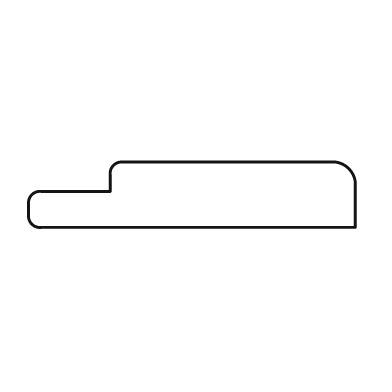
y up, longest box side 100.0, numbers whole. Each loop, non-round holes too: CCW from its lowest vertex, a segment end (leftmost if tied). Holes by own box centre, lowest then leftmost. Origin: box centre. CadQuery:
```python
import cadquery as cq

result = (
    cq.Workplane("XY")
    .moveTo(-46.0, -10.0)
    .lineTo(50.0, -10.0)
    .lineTo(50.0, 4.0)
    .threePointArc((48.0, 8.0), (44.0, 10.0))
    .lineTo(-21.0, 10.0)
    .threePointArc((-24.0, 9.0), (-25.0, 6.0))
    .lineTo(-25.0, 1.0)
    .lineTo(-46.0, 1.0)
    .threePointArc((-49.0, 0.0), (-50.0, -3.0))
    .lineTo(-50.0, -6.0)
    .threePointArc((-49.0, -9.0), (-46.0, -10.0))
    .close()
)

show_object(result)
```